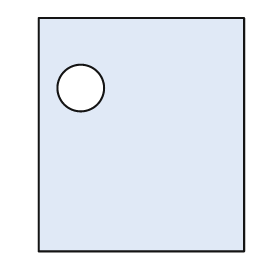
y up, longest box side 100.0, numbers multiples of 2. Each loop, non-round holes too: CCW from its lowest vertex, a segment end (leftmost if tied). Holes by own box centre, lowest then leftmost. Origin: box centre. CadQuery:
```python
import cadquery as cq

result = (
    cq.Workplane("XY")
    .moveTo(-44.0, -50.0)
    .lineTo(44.0, -50.0)
    .lineTo(44.0, 50.0)
    .lineTo(-44.0, 50.0)
    .close()
    .moveTo(-26.0, 20.0)
    .circle(10.0)
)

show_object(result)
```